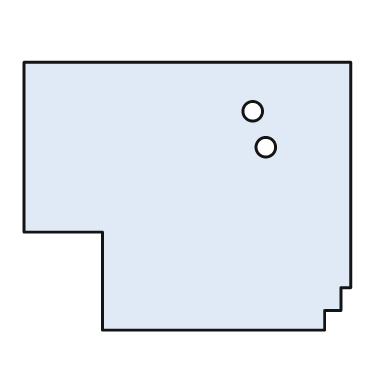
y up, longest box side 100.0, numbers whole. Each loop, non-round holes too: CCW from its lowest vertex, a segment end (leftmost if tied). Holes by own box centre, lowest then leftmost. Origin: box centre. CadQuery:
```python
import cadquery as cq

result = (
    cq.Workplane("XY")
    .moveTo(-26.0, -41.0)
    .lineTo(42.0, -41.0)
    .lineTo(42.0, -35.0)
    .lineTo(47.0, -35.0)
    .lineTo(47.0, -28.0)
    .lineTo(50.0, -28.0)
    .lineTo(50.0, 41.0)
    .lineTo(-50.0, 41.0)
    .lineTo(-50.0, -11.0)
    .lineTo(-26.0, -11.0)
    .close()
    .moveTo(24.0, 15.0)
    .circle(3.0)
    .moveTo(20.0, 26.0)
    .circle(3.0)
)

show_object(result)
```